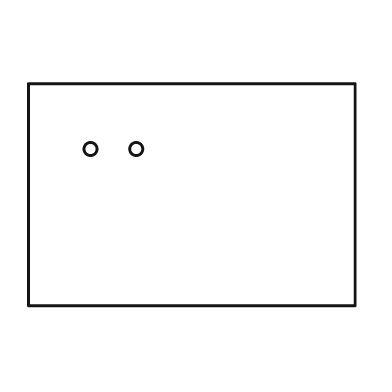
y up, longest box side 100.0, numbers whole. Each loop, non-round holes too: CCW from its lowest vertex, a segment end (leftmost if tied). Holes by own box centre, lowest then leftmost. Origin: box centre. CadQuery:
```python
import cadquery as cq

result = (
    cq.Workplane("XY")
    .moveTo(-50.0, -34.0)
    .lineTo(50.0, -34.0)
    .lineTo(50.0, 34.0)
    .lineTo(-50.0, 34.0)
    .close()
    .moveTo(-31.0, 14.0)
    .circle(2.0)
    .moveTo(-17.0, 14.0)
    .circle(2.0)
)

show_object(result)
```